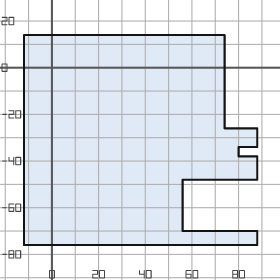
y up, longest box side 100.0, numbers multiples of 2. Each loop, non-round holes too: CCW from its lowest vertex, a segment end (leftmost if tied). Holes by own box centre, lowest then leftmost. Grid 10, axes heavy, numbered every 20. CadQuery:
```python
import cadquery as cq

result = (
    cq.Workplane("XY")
    .moveTo(-12.0, -76.0)
    .lineTo(88.0, -76.0)
    .lineTo(88.0, -70.0)
    .lineTo(56.0, -70.0)
    .lineTo(56.0, -48.0)
    .lineTo(88.0, -48.0)
    .lineTo(88.0, -38.0)
    .lineTo(80.0, -38.0)
    .lineTo(80.0, -34.0)
    .lineTo(88.0, -34.0)
    .lineTo(88.0, -26.0)
    .lineTo(74.0, -26.0)
    .lineTo(74.0, 14.0)
    .lineTo(-12.0, 14.0)
    .close()
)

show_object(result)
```